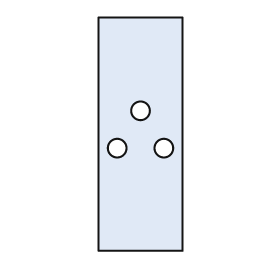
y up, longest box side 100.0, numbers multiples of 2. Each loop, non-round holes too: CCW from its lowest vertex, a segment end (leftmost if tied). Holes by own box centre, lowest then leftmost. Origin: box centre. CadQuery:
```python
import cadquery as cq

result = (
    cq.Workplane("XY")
    .moveTo(-18.0, -50.0)
    .lineTo(18.0, -50.0)
    .lineTo(18.0, 50.0)
    .lineTo(-18.0, 50.0)
    .close()
    .moveTo(-10.0, -6.0)
    .circle(4.0)
    .moveTo(10.0, -6.0)
    .circle(4.0)
    .moveTo(0.0, 10.0)
    .circle(4.0)
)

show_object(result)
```